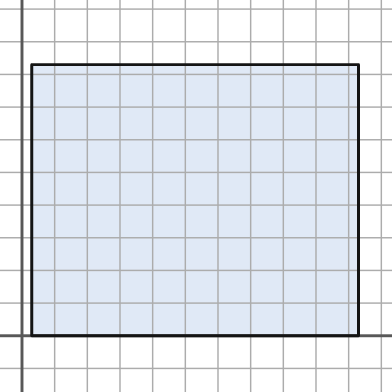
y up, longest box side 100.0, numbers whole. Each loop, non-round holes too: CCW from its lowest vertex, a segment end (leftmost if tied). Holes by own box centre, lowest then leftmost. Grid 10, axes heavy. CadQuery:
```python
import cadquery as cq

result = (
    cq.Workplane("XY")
    .moveTo(3.0, 0.0)
    .lineTo(103.0, 0.0)
    .lineTo(103.0, 83.0)
    .lineTo(3.0, 83.0)
    .close()
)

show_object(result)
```